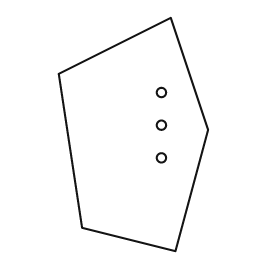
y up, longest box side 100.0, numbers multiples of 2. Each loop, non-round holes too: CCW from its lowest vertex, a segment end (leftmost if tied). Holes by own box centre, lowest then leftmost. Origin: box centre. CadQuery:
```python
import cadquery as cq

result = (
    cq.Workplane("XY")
    .moveTo(18.0, -50.0)
    .lineTo(32.0, 2.0)
    .lineTo(16.0, 50.0)
    .lineTo(-32.0, 26.0)
    .lineTo(-22.0, -40.0)
    .close()
    .moveTo(12.0, -10.0)
    .circle(2.0)
    .moveTo(12.0, 4.0)
    .circle(2.0)
    .moveTo(12.0, 18.0)
    .circle(2.0)
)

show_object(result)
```